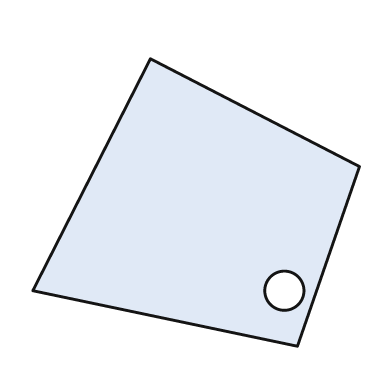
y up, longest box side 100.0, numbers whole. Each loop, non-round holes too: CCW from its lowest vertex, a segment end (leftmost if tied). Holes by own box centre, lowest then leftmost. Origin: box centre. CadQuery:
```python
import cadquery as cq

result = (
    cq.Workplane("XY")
    .moveTo(31.0, -44.0)
    .lineTo(50.0, 11.0)
    .lineTo(-14.0, 44.0)
    .lineTo(-50.0, -27.0)
    .close()
    .moveTo(27.0, -27.0)
    .circle(6.0)
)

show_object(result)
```